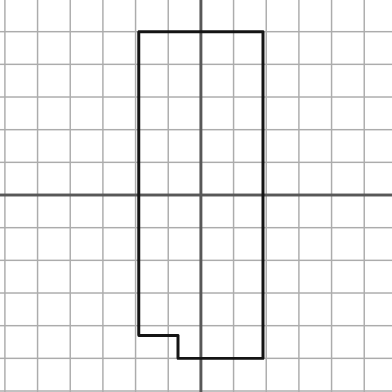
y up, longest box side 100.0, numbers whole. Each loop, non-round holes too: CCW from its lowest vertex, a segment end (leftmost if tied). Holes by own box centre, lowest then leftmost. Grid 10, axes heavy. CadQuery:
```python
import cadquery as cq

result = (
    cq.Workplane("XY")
    .moveTo(-7.0, -50.0)
    .lineTo(19.0, -50.0)
    .lineTo(19.0, 50.0)
    .lineTo(-19.0, 50.0)
    .lineTo(-19.0, -43.0)
    .lineTo(-7.0, -43.0)
    .close()
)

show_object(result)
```